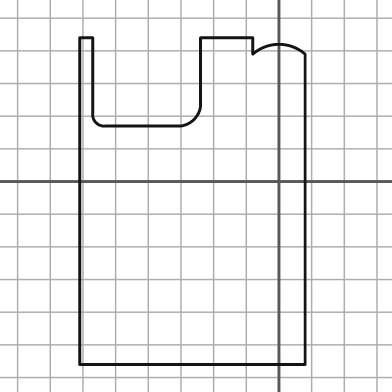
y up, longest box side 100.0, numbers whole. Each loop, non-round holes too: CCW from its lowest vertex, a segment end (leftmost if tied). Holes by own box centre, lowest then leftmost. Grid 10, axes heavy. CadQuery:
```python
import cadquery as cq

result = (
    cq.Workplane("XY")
    .moveTo(-61.0, -56.0)
    .lineTo(8.0, -56.0)
    .lineTo(8.0, 39.0)
    .threePointArc((0.0, 42.0), (-8.0, 39.0))
    .lineTo(-8.0, 44.0)
    .lineTo(-24.0, 44.0)
    .lineTo(-24.0, 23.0)
    .threePointArc((-26.0, 19.0), (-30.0, 17.0))
    .lineTo(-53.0, 17.0)
    .threePointArc((-56.0, 18.0), (-57.0, 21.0))
    .lineTo(-57.0, 44.0)
    .lineTo(-61.0, 44.0)
    .close()
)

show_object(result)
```